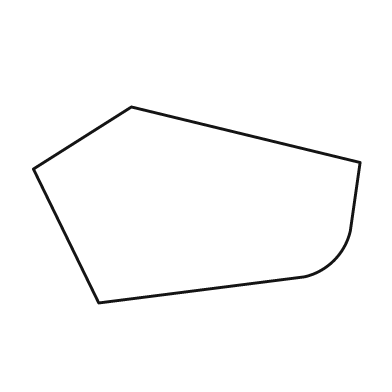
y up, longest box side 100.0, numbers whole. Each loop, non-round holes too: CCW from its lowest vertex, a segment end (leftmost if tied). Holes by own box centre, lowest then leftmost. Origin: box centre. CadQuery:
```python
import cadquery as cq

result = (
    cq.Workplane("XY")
    .moveTo(-30.0, -30.0)
    .lineTo(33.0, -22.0)
    .threePointArc((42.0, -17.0), (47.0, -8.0))
    .lineTo(50.0, 13.0)
    .lineTo(-20.0, 30.0)
    .lineTo(-50.0, 11.0)
    .close()
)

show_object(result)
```